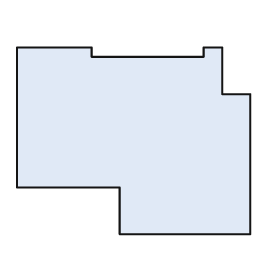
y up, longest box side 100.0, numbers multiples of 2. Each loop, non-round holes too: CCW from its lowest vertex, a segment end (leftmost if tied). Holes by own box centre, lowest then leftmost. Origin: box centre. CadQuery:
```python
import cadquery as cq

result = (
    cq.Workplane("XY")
    .moveTo(-6.0, -40.0)
    .lineTo(50.0, -40.0)
    .lineTo(50.0, 20.0)
    .lineTo(38.0, 20.0)
    .lineTo(38.0, 40.0)
    .lineTo(30.0, 40.0)
    .lineTo(30.0, 36.0)
    .lineTo(-18.0, 36.0)
    .lineTo(-18.0, 40.0)
    .lineTo(-50.0, 40.0)
    .lineTo(-50.0, -20.0)
    .lineTo(-6.0, -20.0)
    .close()
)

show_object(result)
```